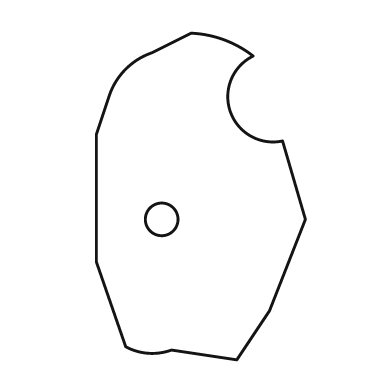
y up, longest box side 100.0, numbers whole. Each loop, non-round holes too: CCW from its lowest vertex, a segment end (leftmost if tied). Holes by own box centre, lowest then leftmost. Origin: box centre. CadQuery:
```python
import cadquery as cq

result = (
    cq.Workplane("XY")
    .moveTo(11.0, -50.0)
    .lineTo(21.0, -35.0)
    .lineTo(32.0, -7.0)
    .lineTo(25.0, 17.0)
    .threePointArc((9.0, 26.0), (16.0, 43.0))
    .threePointArc((7.0, 48.0), (-3.0, 50.0))
    .lineTo(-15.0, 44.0)
    .threePointArc((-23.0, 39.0), (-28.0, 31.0))
    .lineTo(-32.0, 19.0)
    .lineTo(-32.0, -20.0)
    .lineTo(-23.0, -46.0)
    .threePointArc((-16.0, -48.0), (-9.0, -47.0))
    .close()
    .moveTo(-12.0, -7.0)
    .circle(5.0)
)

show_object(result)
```